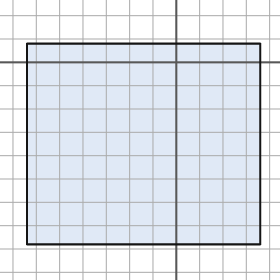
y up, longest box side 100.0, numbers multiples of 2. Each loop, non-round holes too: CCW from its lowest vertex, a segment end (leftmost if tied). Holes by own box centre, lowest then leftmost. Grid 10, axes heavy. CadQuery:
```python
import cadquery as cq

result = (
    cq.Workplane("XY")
    .moveTo(-64.0, -78.0)
    .lineTo(36.0, -78.0)
    .lineTo(36.0, 8.0)
    .lineTo(-64.0, 8.0)
    .close()
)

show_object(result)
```